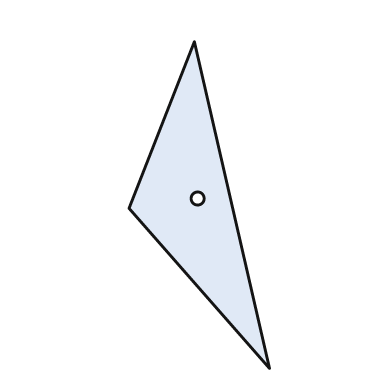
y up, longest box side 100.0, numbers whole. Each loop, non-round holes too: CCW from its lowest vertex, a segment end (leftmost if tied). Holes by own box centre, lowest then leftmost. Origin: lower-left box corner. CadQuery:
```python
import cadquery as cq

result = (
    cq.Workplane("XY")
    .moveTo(43.0, 0.0)
    .lineTo(20.0, 100.0)
    .lineTo(0.0, 49.0)
    .close()
    .moveTo(21.0, 52.0)
    .circle(2.0)
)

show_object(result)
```